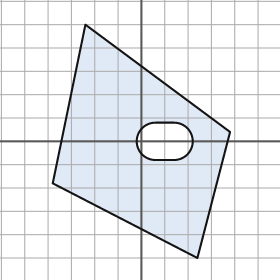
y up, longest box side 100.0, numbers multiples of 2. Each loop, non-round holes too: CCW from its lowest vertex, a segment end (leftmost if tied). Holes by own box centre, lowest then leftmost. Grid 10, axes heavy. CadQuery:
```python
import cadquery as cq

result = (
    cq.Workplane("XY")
    .moveTo(24.0, -50.0)
    .lineTo(38.0, 4.0)
    .lineTo(-24.0, 50.0)
    .lineTo(-38.0, -18.0)
    .close()
    .moveTo(6.0, -8.0)
    .lineTo(14.0, -8.0)
    .threePointArc((22.0, 0.0), (14.0, 8.0))
    .lineTo(6.0, 8.0)
    .threePointArc((-2.0, 0.0), (6.0, -8.0))
    .close()
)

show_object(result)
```